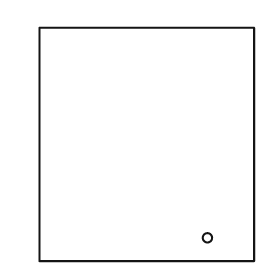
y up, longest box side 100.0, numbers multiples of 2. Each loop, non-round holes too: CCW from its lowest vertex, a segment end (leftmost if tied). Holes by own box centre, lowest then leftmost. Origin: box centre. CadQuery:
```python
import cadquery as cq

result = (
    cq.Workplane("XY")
    .moveTo(-46.0, -50.0)
    .lineTo(46.0, -50.0)
    .lineTo(46.0, 50.0)
    .lineTo(-46.0, 50.0)
    .close()
    .moveTo(26.0, -40.0)
    .circle(2.0)
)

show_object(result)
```